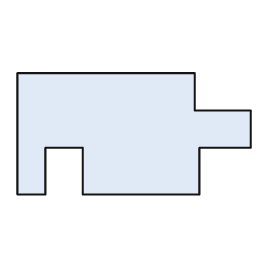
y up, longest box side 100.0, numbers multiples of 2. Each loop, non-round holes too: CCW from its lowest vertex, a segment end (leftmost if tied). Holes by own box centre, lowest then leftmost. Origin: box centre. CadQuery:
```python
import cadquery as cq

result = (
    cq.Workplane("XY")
    .moveTo(-50.0, -26.0)
    .lineTo(-38.0, -26.0)
    .lineTo(-38.0, -6.0)
    .lineTo(-22.0, -6.0)
    .lineTo(-22.0, -26.0)
    .lineTo(28.0, -26.0)
    .lineTo(28.0, -6.0)
    .lineTo(50.0, -6.0)
    .lineTo(50.0, 10.0)
    .lineTo(26.0, 10.0)
    .lineTo(26.0, 26.0)
    .lineTo(-50.0, 26.0)
    .close()
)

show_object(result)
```